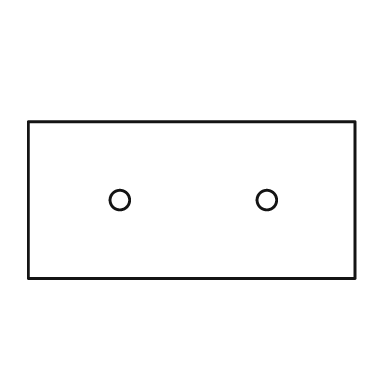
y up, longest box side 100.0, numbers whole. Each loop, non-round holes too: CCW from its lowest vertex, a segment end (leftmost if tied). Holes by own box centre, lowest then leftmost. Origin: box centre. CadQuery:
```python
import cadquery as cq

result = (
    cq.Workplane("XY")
    .moveTo(-50.0, -24.0)
    .lineTo(50.0, -24.0)
    .lineTo(50.0, 24.0)
    .lineTo(-50.0, 24.0)
    .close()
    .moveTo(-22.0, 0.0)
    .circle(3.0)
    .moveTo(23.0, 0.0)
    .circle(3.0)
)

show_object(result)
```